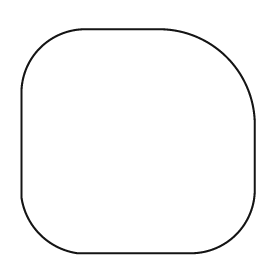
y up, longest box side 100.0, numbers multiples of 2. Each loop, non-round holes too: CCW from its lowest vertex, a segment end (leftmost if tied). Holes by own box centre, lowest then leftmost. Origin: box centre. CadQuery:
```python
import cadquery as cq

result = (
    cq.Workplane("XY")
    .moveTo(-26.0, -48.0)
    .lineTo(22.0, -48.0)
    .threePointArc((42.0, -40.0), (50.0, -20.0))
    .lineTo(50.0, 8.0)
    .threePointArc((38.0, 36.0), (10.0, 48.0))
    .lineTo(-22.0, 48.0)
    .threePointArc((-42.0, 40.0), (-50.0, 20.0))
    .lineTo(-50.0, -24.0)
    .threePointArc((-42.0, -40.0), (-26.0, -48.0))
    .close()
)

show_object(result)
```